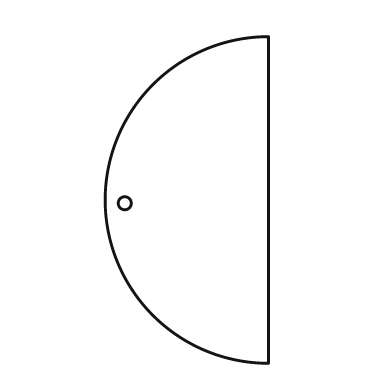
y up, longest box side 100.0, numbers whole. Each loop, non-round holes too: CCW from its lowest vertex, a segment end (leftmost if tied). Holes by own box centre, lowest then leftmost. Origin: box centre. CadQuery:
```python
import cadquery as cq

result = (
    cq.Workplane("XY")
    .moveTo(25.0, -50.0)
    .lineTo(25.0, 50.0)
    .threePointArc((-25.0, 0.0), (25.0, -50.0))
    .close()
    .moveTo(-19.0, -1.0)
    .circle(2.0)
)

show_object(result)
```